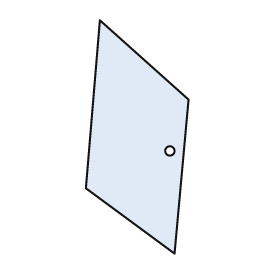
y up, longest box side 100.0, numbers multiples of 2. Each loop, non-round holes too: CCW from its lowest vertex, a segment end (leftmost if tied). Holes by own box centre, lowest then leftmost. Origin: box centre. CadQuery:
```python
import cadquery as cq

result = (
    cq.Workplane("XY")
    .moveTo(16.0, -50.0)
    .lineTo(22.0, 16.0)
    .lineTo(-16.0, 50.0)
    .lineTo(-22.0, -22.0)
    .close()
    .moveTo(14.0, -6.0)
    .circle(2.0)
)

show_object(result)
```